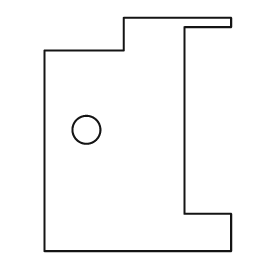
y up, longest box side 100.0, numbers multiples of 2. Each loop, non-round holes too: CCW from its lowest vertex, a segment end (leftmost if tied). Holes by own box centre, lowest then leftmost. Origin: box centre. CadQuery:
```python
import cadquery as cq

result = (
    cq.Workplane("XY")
    .moveTo(-40.0, -50.0)
    .lineTo(40.0, -50.0)
    .lineTo(40.0, -34.0)
    .lineTo(20.0, -34.0)
    .lineTo(20.0, 46.0)
    .lineTo(40.0, 46.0)
    .lineTo(40.0, 50.0)
    .lineTo(-6.0, 50.0)
    .lineTo(-6.0, 36.0)
    .lineTo(-40.0, 36.0)
    .close()
    .moveTo(-22.0, 2.0)
    .circle(6.0)
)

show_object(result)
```